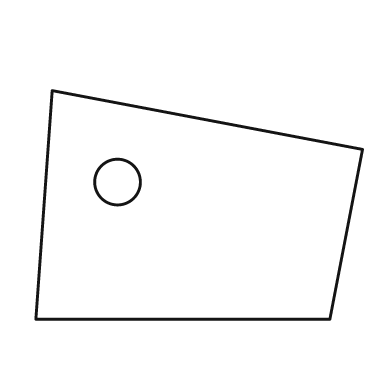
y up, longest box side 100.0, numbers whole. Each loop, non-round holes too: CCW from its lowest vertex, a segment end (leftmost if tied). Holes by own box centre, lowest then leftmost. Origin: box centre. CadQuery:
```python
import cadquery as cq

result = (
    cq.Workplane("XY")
    .moveTo(-50.0, -35.0)
    .lineTo(40.0, -35.0)
    .lineTo(50.0, 17.0)
    .lineTo(-45.0, 35.0)
    .close()
    .moveTo(-25.0, 7.0)
    .circle(7.0)
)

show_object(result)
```